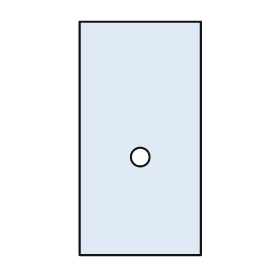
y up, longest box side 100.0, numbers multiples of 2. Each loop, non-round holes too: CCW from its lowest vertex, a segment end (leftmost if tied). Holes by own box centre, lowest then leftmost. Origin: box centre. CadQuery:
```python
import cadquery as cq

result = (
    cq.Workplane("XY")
    .moveTo(-26.0, -50.0)
    .lineTo(26.0, -50.0)
    .lineTo(26.0, 50.0)
    .lineTo(-26.0, 50.0)
    .close()
    .moveTo(0.0, -8.0)
    .circle(4.0)
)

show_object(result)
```